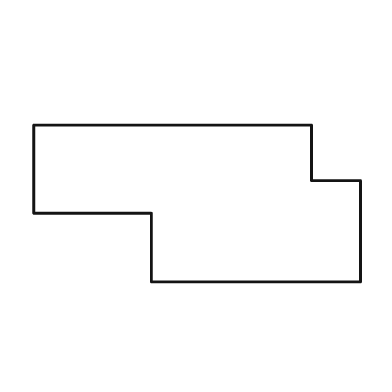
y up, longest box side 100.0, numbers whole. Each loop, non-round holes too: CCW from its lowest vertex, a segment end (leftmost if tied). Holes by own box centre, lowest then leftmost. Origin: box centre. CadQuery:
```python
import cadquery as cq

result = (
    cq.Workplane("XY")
    .moveTo(-14.0, -24.0)
    .lineTo(50.0, -24.0)
    .lineTo(50.0, 7.0)
    .lineTo(35.0, 7.0)
    .lineTo(35.0, 24.0)
    .lineTo(-50.0, 24.0)
    .lineTo(-50.0, -3.0)
    .lineTo(-14.0, -3.0)
    .close()
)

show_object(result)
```